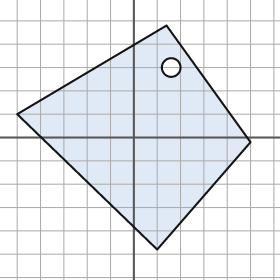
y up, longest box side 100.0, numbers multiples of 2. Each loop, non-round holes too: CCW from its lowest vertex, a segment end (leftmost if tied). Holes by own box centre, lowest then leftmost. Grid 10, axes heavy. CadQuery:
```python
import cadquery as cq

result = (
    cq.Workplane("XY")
    .moveTo(10.0, -48.0)
    .lineTo(50.0, -2.0)
    .lineTo(14.0, 48.0)
    .lineTo(-50.0, 10.0)
    .close()
    .moveTo(16.0, 30.0)
    .circle(4.0)
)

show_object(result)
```